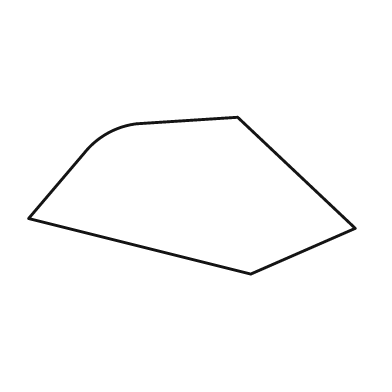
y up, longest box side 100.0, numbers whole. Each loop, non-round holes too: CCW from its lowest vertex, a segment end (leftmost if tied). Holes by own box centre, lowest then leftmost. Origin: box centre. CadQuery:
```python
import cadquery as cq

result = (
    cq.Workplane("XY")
    .moveTo(18.0, -24.0)
    .lineTo(50.0, -10.0)
    .lineTo(14.0, 24.0)
    .lineTo(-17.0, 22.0)
    .threePointArc((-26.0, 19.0), (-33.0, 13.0))
    .lineTo(-50.0, -7.0)
    .close()
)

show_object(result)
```